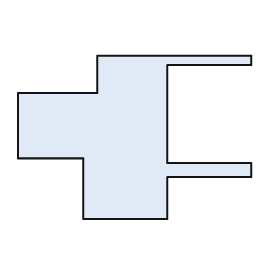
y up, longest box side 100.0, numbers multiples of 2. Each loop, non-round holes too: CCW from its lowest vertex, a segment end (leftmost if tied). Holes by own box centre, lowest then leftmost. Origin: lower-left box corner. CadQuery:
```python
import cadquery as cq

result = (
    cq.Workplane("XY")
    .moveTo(28.0, 0.0)
    .lineTo(64.0, 0.0)
    .lineTo(64.0, 18.0)
    .lineTo(100.0, 18.0)
    .lineTo(100.0, 24.0)
    .lineTo(64.0, 24.0)
    .lineTo(64.0, 66.0)
    .lineTo(100.0, 66.0)
    .lineTo(100.0, 70.0)
    .lineTo(34.0, 70.0)
    .lineTo(34.0, 54.0)
    .lineTo(0.0, 54.0)
    .lineTo(0.0, 26.0)
    .lineTo(28.0, 26.0)
    .close()
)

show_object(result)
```